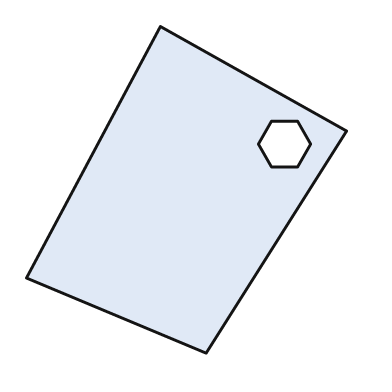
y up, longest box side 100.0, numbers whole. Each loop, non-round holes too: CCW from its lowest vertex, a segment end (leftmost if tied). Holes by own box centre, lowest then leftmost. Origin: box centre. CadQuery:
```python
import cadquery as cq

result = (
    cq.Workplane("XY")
    .moveTo(6.0, -50.0)
    .lineTo(49.0, 18.0)
    .lineTo(-8.0, 50.0)
    .lineTo(-49.0, -27.0)
    .close()
    .moveTo(26.0, 7.0)
    .lineTo(34.0, 7.0)
    .lineTo(38.0, 14.0)
    .lineTo(34.0, 21.0)
    .lineTo(26.0, 21.0)
    .lineTo(22.0, 14.0)
    .close()
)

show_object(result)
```